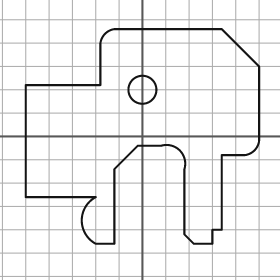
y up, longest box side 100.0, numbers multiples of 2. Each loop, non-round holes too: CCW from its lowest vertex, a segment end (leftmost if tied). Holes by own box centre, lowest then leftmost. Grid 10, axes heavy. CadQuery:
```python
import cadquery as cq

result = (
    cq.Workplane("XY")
    .moveTo(-20.0, -46.0)
    .lineTo(-12.0, -46.0)
    .lineTo(-12.0, -14.0)
    .lineTo(-2.0, -4.0)
    .lineTo(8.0, -4.0)
    .threePointArc((16.0, -6.0), (18.0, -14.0))
    .lineTo(18.0, -42.0)
    .lineTo(22.0, -46.0)
    .lineTo(30.0, -46.0)
    .lineTo(30.0, -40.0)
    .lineTo(34.0, -40.0)
    .lineTo(34.0, -8.0)
    .lineTo(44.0, -8.0)
    .threePointArc((48.0, -6.0), (50.0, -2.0))
    .lineTo(50.0, 30.0)
    .lineTo(34.0, 46.0)
    .lineTo(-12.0, 46.0)
    .threePointArc((-16.0, 44.0), (-18.0, 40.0))
    .lineTo(-18.0, 22.0)
    .lineTo(-50.0, 22.0)
    .lineTo(-50.0, -26.0)
    .lineTo(-20.0, -26.0)
    .threePointArc((-26.0, -36.0), (-20.0, -46.0))
    .close()
    .moveTo(0.0, 20.0)
    .circle(6.0)
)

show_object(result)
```